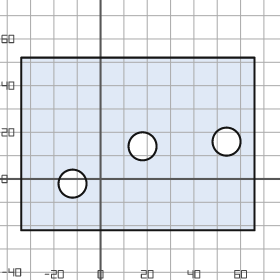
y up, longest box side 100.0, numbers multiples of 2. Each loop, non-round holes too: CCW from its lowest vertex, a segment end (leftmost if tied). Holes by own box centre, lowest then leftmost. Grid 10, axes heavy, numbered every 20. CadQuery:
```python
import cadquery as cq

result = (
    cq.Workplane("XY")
    .moveTo(-34.0, -22.0)
    .lineTo(66.0, -22.0)
    .lineTo(66.0, 52.0)
    .lineTo(-34.0, 52.0)
    .close()
    .moveTo(-12.0, -2.0)
    .circle(6.0)
    .moveTo(18.0, 14.0)
    .circle(6.0)
    .moveTo(54.0, 16.0)
    .circle(6.0)
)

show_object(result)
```